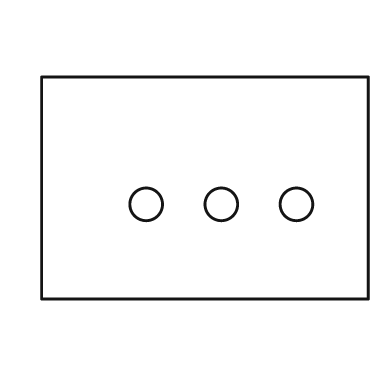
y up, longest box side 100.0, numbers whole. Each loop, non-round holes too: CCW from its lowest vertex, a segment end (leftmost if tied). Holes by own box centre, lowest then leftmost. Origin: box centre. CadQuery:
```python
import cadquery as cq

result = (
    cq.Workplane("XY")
    .moveTo(-50.0, -34.0)
    .lineTo(50.0, -34.0)
    .lineTo(50.0, 34.0)
    .lineTo(-50.0, 34.0)
    .close()
    .moveTo(-18.0, -5.0)
    .circle(5.0)
    .moveTo(5.0, -5.0)
    .circle(5.0)
    .moveTo(28.0, -5.0)
    .circle(5.0)
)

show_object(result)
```